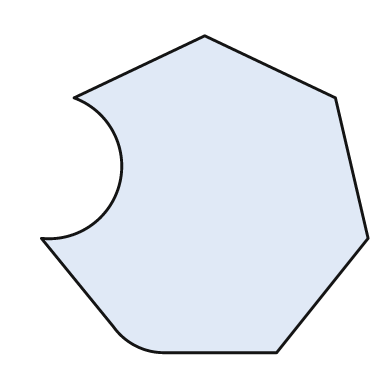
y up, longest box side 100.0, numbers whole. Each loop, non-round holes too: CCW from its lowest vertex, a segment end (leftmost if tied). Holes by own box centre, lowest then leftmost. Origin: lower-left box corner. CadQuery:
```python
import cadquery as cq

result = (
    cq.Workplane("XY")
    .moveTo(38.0, 0.0)
    .lineTo(72.0, 0.0)
    .lineTo(100.0, 35.0)
    .lineTo(90.0, 78.0)
    .lineTo(50.0, 97.0)
    .lineTo(10.0, 78.0)
    .threePointArc((24.0, 52.0), (0.0, 35.0))
    .lineTo(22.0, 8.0)
    .threePointArc((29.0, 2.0), (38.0, 0.0))
    .close()
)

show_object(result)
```